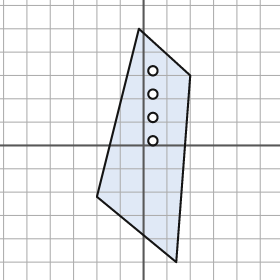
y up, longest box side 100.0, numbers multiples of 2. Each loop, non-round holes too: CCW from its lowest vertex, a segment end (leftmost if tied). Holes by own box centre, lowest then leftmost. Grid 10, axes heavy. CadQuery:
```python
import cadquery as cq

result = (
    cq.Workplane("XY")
    .moveTo(14.0, -50.0)
    .lineTo(20.0, 30.0)
    .lineTo(-2.0, 50.0)
    .lineTo(-20.0, -22.0)
    .close()
    .moveTo(4.0, 2.0)
    .circle(2.0)
    .moveTo(4.0, 12.0)
    .circle(2.0)
    .moveTo(4.0, 22.0)
    .circle(2.0)
    .moveTo(4.0, 32.0)
    .circle(2.0)
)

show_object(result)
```